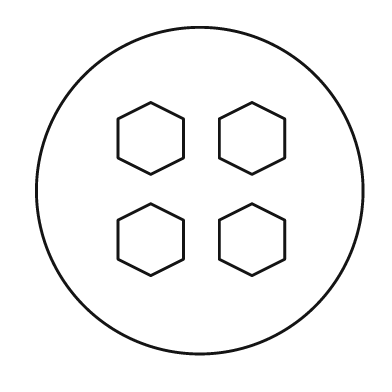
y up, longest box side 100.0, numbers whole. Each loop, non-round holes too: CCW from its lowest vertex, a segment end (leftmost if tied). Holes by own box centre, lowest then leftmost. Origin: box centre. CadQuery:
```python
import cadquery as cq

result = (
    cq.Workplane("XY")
    .moveTo(0.0, 0.0)
    .circle(50.0)
    .moveTo(-15.0, -26.0)
    .lineTo(-5.0, -21.0)
    .lineTo(-5.0, -9.0)
    .lineTo(-15.0, -4.0)
    .lineTo(-25.0, -9.0)
    .lineTo(-25.0, -21.0)
    .close()
    .moveTo(16.0, -26.0)
    .lineTo(26.0, -21.0)
    .lineTo(26.0, -9.0)
    .lineTo(16.0, -4.0)
    .lineTo(6.0, -9.0)
    .lineTo(6.0, -21.0)
    .close()
    .moveTo(-15.0, 5.0)
    .lineTo(-5.0, 10.0)
    .lineTo(-5.0, 22.0)
    .lineTo(-15.0, 27.0)
    .lineTo(-25.0, 22.0)
    .lineTo(-25.0, 10.0)
    .close()
    .moveTo(16.0, 5.0)
    .lineTo(26.0, 10.0)
    .lineTo(26.0, 22.0)
    .lineTo(16.0, 27.0)
    .lineTo(6.0, 22.0)
    .lineTo(6.0, 10.0)
    .close()
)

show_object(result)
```